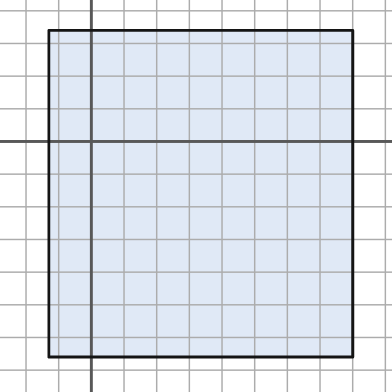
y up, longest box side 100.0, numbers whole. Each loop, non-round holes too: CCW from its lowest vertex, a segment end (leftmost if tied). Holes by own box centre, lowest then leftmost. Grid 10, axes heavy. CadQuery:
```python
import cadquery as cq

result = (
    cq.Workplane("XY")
    .moveTo(-13.0, -66.0)
    .lineTo(80.0, -66.0)
    .lineTo(80.0, 34.0)
    .lineTo(-13.0, 34.0)
    .close()
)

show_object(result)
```